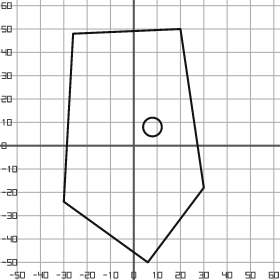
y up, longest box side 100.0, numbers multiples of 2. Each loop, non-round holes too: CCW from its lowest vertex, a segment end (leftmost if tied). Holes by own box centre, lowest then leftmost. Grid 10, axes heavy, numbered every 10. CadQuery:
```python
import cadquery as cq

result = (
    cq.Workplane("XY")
    .moveTo(6.0, -50.0)
    .lineTo(30.0, -18.0)
    .lineTo(20.0, 50.0)
    .lineTo(-26.0, 48.0)
    .lineTo(-30.0, -24.0)
    .close()
    .moveTo(8.0, 8.0)
    .circle(4.0)
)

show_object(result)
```